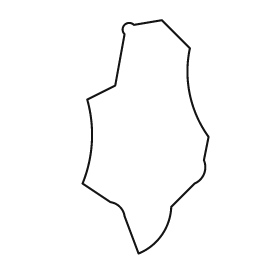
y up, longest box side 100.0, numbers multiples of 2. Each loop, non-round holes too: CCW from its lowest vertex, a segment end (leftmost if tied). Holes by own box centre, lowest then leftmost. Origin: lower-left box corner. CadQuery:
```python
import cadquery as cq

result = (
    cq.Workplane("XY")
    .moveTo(24.0, 0.0)
    .threePointArc((34.0, 8.0), (38.0, 20.0))
    .lineTo(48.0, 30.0)
    .threePointArc((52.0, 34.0), (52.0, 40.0))
    .lineTo(54.0, 50.0)
    .threePointArc((46.0, 68.0), (46.0, 88.0))
    .lineTo(34.0, 100.0)
    .lineTo(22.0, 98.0)
    .threePointArc((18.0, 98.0), (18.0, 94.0))
    .lineTo(14.0, 72.0)
    .lineTo(2.0, 66.0)
    .threePointArc((4.0, 48.0), (0.0, 30.0))
    .lineTo(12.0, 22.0)
    .threePointArc((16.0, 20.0), (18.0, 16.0))
    .close()
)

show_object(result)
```